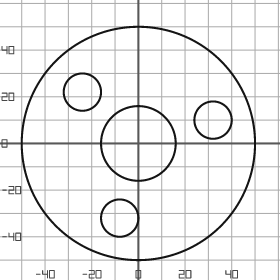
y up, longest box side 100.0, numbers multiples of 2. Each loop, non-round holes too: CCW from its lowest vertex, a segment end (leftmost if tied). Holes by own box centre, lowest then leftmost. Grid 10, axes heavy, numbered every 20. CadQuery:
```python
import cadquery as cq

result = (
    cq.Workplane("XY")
    .moveTo(0.0, 0.0)
    .circle(50.0)
    .moveTo(-8.0, -32.0)
    .circle(8.0)
    .moveTo(0.0, 0.0)
    .circle(16.0)
    .moveTo(32.0, 10.0)
    .circle(8.0)
    .moveTo(-24.0, 22.0)
    .circle(8.0)
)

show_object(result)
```